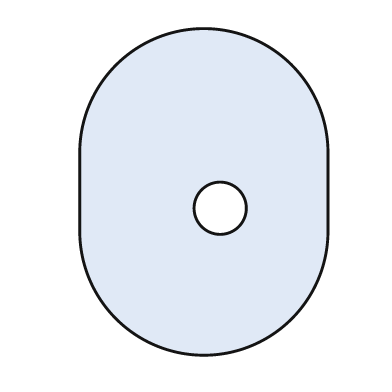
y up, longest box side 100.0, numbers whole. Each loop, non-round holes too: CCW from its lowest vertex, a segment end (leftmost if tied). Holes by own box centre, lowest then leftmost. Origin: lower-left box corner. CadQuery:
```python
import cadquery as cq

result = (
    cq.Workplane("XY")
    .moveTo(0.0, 38.0)
    .threePointArc((38.0, 0.0), (76.0, 38.0))
    .lineTo(76.0, 62.0)
    .threePointArc((38.0, 100.0), (0.0, 62.0))
    .close()
    .moveTo(43.0, 45.0)
    .circle(8.0)
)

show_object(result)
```